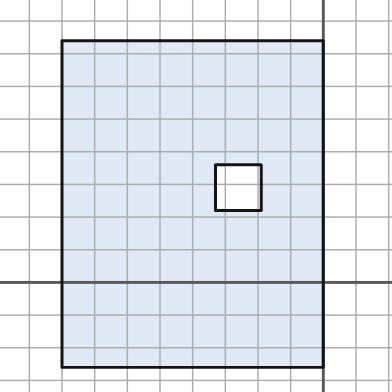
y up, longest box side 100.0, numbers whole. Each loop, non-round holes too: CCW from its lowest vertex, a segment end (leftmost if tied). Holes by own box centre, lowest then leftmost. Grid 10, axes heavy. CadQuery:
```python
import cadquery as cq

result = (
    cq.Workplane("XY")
    .moveTo(-80.0, -26.0)
    .lineTo(0.0, -26.0)
    .lineTo(0.0, 74.0)
    .lineTo(-80.0, 74.0)
    .close()
    .moveTo(-33.0, 22.0)
    .lineTo(-19.0, 22.0)
    .lineTo(-19.0, 36.0)
    .lineTo(-33.0, 36.0)
    .close()
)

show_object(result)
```